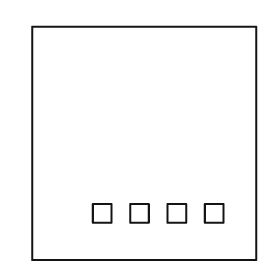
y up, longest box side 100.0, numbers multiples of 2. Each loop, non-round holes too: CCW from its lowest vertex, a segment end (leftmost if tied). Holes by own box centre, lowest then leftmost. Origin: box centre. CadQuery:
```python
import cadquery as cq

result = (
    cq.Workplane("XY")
    .moveTo(-48.0, -50.0)
    .lineTo(48.0, -50.0)
    .lineTo(48.0, 50.0)
    .lineTo(-48.0, 50.0)
    .close()
    .moveTo(-22.0, -34.0)
    .lineTo(-14.0, -34.0)
    .lineTo(-14.0, -26.0)
    .lineTo(-22.0, -26.0)
    .close()
    .moveTo(-6.0, -34.0)
    .lineTo(2.0, -34.0)
    .lineTo(2.0, -26.0)
    .lineTo(-6.0, -26.0)
    .close()
    .moveTo(10.0, -34.0)
    .lineTo(18.0, -34.0)
    .lineTo(18.0, -26.0)
    .lineTo(10.0, -26.0)
    .close()
    .moveTo(26.0, -34.0)
    .lineTo(34.0, -34.0)
    .lineTo(34.0, -26.0)
    .lineTo(26.0, -26.0)
    .close()
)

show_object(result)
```